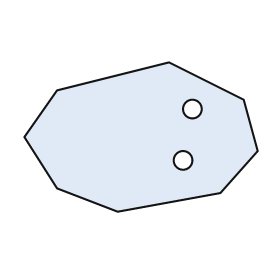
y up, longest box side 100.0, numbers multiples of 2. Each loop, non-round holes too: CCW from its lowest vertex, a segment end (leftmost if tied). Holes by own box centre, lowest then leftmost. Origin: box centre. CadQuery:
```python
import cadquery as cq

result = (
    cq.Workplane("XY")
    .moveTo(-10.0, -32.0)
    .lineTo(34.0, -24.0)
    .lineTo(50.0, -6.0)
    .lineTo(44.0, 16.0)
    .lineTo(12.0, 32.0)
    .lineTo(-36.0, 20.0)
    .lineTo(-50.0, 0.0)
    .lineTo(-36.0, -22.0)
    .close()
    .moveTo(18.0, -10.0)
    .circle(4.0)
    .moveTo(22.0, 12.0)
    .circle(4.0)
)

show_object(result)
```